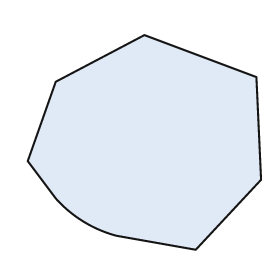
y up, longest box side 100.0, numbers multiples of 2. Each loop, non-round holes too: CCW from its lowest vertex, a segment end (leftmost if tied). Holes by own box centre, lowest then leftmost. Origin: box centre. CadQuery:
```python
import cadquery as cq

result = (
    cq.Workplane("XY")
    .moveTo(22.0, -46.0)
    .lineTo(50.0, -16.0)
    .lineTo(48.0, 28.0)
    .lineTo(0.0, 46.0)
    .lineTo(-38.0, 26.0)
    .lineTo(-50.0, -8.0)
    .lineTo(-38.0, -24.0)
    .threePointArc((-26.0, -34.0), (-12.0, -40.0))
    .close()
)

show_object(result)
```